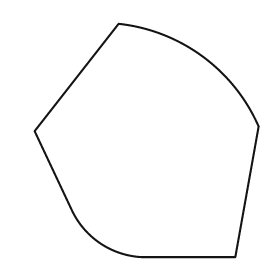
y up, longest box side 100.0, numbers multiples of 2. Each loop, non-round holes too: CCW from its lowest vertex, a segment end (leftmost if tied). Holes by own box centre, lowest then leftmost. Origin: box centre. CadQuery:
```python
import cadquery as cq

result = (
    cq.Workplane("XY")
    .moveTo(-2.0, -50.0)
    .lineTo(38.0, -50.0)
    .lineTo(48.0, 6.0)
    .threePointArc((24.0, 36.0), (-12.0, 50.0))
    .lineTo(-48.0, 4.0)
    .lineTo(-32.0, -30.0)
    .threePointArc((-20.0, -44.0), (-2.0, -50.0))
    .close()
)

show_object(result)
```